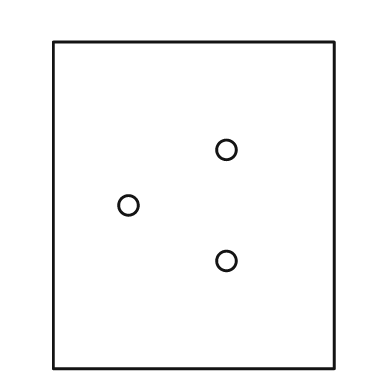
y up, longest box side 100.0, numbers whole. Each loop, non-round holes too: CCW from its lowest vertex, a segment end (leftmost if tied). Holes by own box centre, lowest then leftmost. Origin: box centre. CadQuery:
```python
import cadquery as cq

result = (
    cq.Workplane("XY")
    .moveTo(-43.0, -50.0)
    .lineTo(43.0, -50.0)
    .lineTo(43.0, 50.0)
    .lineTo(-43.0, 50.0)
    .close()
    .moveTo(10.0, -17.0)
    .circle(3.0)
    .moveTo(-20.0, 0.0)
    .circle(3.0)
    .moveTo(10.0, 17.0)
    .circle(3.0)
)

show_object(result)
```